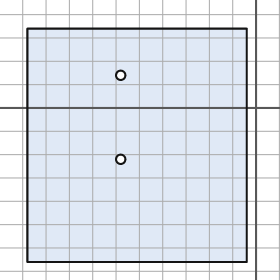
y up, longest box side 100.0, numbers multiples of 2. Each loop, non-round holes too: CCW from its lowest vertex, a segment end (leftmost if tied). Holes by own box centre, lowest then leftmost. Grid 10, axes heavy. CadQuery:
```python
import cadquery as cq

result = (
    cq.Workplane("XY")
    .moveTo(-98.0, -66.0)
    .lineTo(-4.0, -66.0)
    .lineTo(-4.0, 34.0)
    .lineTo(-98.0, 34.0)
    .close()
    .moveTo(-58.0, -22.0)
    .circle(2.0)
    .moveTo(-58.0, 14.0)
    .circle(2.0)
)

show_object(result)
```